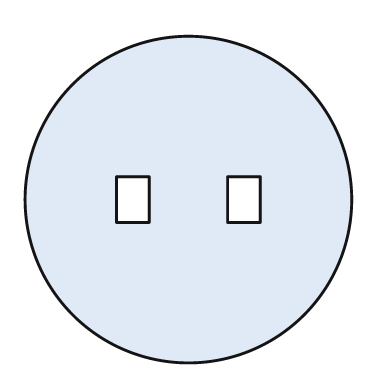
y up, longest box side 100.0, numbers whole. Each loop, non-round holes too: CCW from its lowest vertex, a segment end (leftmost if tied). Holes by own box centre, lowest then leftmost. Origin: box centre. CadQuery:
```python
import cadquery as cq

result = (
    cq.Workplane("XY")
    .moveTo(0.0, 0.0)
    .circle(50.0)
    .moveTo(-22.0, -7.0)
    .lineTo(-12.0, -7.0)
    .lineTo(-12.0, 7.0)
    .lineTo(-22.0, 7.0)
    .close()
    .moveTo(12.0, -7.0)
    .lineTo(22.0, -7.0)
    .lineTo(22.0, 7.0)
    .lineTo(12.0, 7.0)
    .close()
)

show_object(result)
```